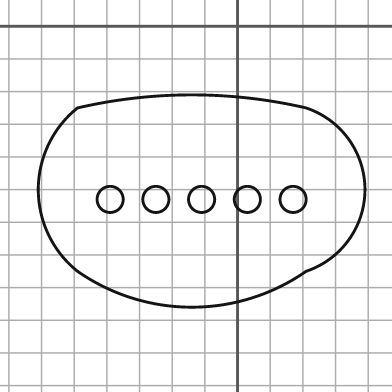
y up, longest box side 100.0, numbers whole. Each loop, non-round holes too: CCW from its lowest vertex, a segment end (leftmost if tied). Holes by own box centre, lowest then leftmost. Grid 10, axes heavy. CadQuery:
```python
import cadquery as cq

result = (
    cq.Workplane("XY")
    .moveTo(-49.0, -75.0)
    .threePointArc((-14.0, -86.0), (21.0, -75.0))
    .threePointArc((39.0, -50.0), (21.0, -25.0))
    .threePointArc((-14.0, -21.0), (-49.0, -25.0))
    .threePointArc((-61.0, -50.0), (-49.0, -75.0))
    .close()
    .moveTo(-39.0, -53.0)
    .circle(4.0)
    .moveTo(-25.0, -53.0)
    .circle(4.0)
    .moveTo(-11.0, -53.0)
    .circle(4.0)
    .moveTo(3.0, -53.0)
    .circle(4.0)
    .moveTo(17.0, -53.0)
    .circle(4.0)
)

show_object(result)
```